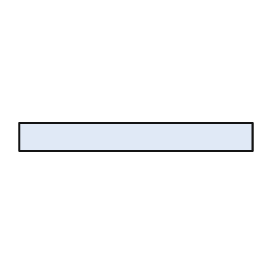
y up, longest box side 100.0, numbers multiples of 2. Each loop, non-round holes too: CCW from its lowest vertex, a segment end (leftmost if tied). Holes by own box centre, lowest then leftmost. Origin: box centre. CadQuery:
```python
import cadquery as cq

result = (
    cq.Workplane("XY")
    .moveTo(-50.0, -6.0)
    .lineTo(50.0, -6.0)
    .lineTo(50.0, 6.0)
    .lineTo(-50.0, 6.0)
    .close()
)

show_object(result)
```